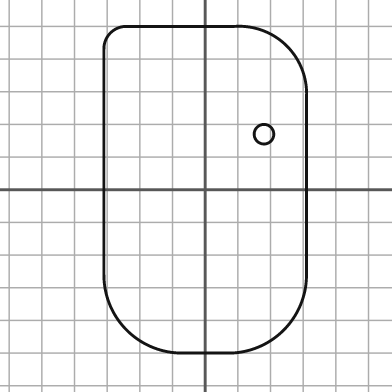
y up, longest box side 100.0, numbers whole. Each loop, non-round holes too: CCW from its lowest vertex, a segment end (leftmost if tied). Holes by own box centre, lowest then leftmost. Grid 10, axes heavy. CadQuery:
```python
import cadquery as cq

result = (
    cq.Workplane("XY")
    .moveTo(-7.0, -50.0)
    .lineTo(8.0, -50.0)
    .threePointArc((24.0, -43.0), (31.0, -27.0))
    .lineTo(31.0, 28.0)
    .threePointArc((25.0, 44.0), (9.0, 50.0))
    .lineTo(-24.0, 50.0)
    .threePointArc((-29.0, 48.0), (-31.0, 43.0))
    .lineTo(-31.0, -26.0)
    .threePointArc((-24.0, -43.0), (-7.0, -50.0))
    .close()
    .moveTo(18.0, 17.0)
    .circle(3.0)
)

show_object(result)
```